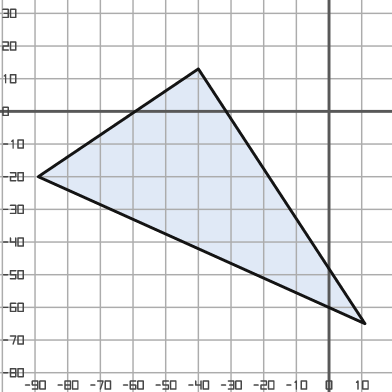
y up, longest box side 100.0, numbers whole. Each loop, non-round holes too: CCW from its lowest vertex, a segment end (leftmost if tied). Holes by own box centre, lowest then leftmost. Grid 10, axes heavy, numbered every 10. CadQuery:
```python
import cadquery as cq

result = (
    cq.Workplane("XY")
    .moveTo(11.0, -65.0)
    .lineTo(-40.0, 13.0)
    .lineTo(-89.0, -20.0)
    .close()
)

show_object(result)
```